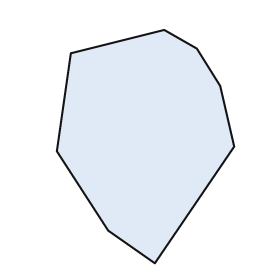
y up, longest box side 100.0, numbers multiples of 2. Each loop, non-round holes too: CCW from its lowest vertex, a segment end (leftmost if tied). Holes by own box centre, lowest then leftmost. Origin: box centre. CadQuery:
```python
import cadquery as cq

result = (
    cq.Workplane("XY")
    .moveTo(4.0, -50.0)
    .lineTo(38.0, 0.0)
    .lineTo(32.0, 26.0)
    .lineTo(22.0, 42.0)
    .lineTo(8.0, 50.0)
    .lineTo(-32.0, 40.0)
    .lineTo(-38.0, -2.0)
    .lineTo(-16.0, -36.0)
    .close()
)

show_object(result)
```